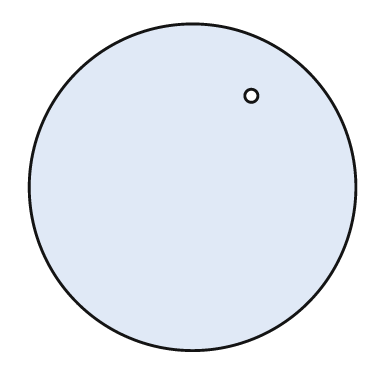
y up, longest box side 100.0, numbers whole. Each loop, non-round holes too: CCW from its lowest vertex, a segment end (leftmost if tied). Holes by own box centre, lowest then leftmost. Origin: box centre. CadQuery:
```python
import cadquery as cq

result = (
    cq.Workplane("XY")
    .moveTo(0.0, 0.0)
    .circle(50.0)
    .moveTo(18.0, 28.0)
    .circle(2.0)
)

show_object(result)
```